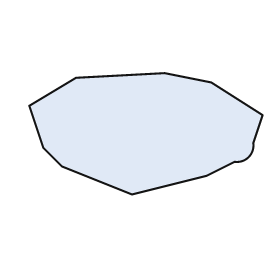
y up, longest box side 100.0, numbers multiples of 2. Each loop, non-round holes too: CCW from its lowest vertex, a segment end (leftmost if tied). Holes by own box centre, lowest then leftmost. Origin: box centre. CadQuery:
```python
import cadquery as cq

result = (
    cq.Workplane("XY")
    .moveTo(-6.0, -26.0)
    .lineTo(26.0, -18.0)
    .lineTo(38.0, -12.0)
    .threePointArc((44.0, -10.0), (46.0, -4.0))
    .lineTo(50.0, 8.0)
    .lineTo(28.0, 22.0)
    .lineTo(8.0, 26.0)
    .lineTo(-30.0, 24.0)
    .lineTo(-50.0, 12.0)
    .lineTo(-44.0, -6.0)
    .lineTo(-36.0, -14.0)
    .close()
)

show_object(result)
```